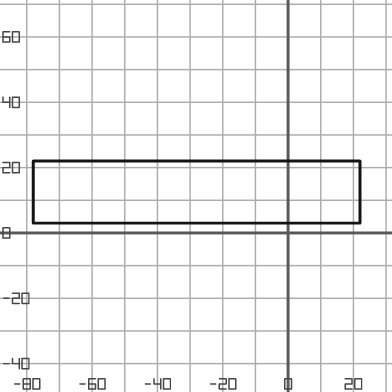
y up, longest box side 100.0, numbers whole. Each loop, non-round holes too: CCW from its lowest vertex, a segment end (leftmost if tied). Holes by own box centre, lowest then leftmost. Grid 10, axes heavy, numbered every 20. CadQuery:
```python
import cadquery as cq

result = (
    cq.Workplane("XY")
    .moveTo(-78.0, 3.0)
    .lineTo(22.0, 3.0)
    .lineTo(22.0, 22.0)
    .lineTo(-78.0, 22.0)
    .close()
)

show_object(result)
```